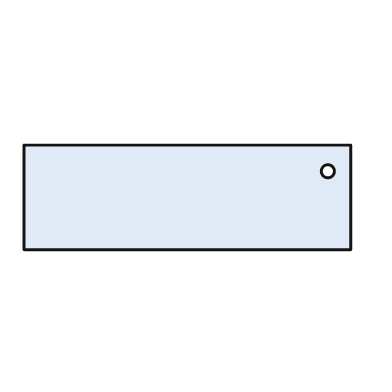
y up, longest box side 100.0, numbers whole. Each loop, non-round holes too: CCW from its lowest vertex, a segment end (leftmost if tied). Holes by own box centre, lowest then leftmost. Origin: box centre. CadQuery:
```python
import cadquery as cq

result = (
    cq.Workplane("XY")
    .moveTo(-50.0, -16.0)
    .lineTo(50.0, -16.0)
    .lineTo(50.0, 16.0)
    .lineTo(-50.0, 16.0)
    .close()
    .moveTo(43.0, 8.0)
    .circle(2.0)
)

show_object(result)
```